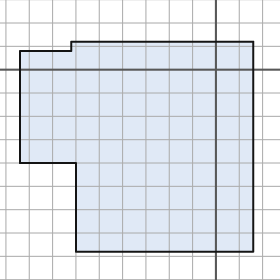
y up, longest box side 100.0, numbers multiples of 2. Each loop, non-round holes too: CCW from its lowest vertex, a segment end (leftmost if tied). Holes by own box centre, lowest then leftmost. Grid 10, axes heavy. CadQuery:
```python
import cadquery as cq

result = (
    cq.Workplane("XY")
    .moveTo(-60.0, -78.0)
    .lineTo(16.0, -78.0)
    .lineTo(16.0, 12.0)
    .lineTo(-62.0, 12.0)
    .lineTo(-62.0, 8.0)
    .lineTo(-84.0, 8.0)
    .lineTo(-84.0, -40.0)
    .lineTo(-60.0, -40.0)
    .close()
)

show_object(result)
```